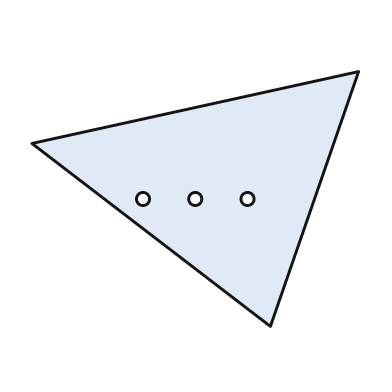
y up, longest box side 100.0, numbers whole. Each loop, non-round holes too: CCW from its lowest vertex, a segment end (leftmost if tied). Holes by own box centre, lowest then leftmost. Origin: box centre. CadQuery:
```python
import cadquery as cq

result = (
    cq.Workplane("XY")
    .moveTo(23.0, -39.0)
    .lineTo(50.0, 39.0)
    .lineTo(-50.0, 17.0)
    .close()
    .moveTo(-16.0, 0.0)
    .circle(2.0)
    .moveTo(0.0, 0.0)
    .circle(2.0)
    .moveTo(16.0, 0.0)
    .circle(2.0)
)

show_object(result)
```